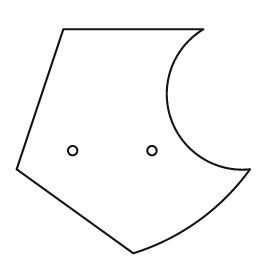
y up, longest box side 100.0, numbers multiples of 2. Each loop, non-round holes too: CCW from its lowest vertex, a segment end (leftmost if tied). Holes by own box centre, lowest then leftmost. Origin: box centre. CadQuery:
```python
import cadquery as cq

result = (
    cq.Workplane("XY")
    .moveTo(0.0, -48.0)
    .threePointArc((28.0, -34.0), (50.0, -12.0))
    .threePointArc((16.0, 10.0), (30.0, 48.0))
    .lineTo(-30.0, 48.0)
    .lineTo(-50.0, -12.0)
    .close()
    .moveTo(-26.0, -4.0)
    .circle(2.0)
    .moveTo(8.0, -4.0)
    .circle(2.0)
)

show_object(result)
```